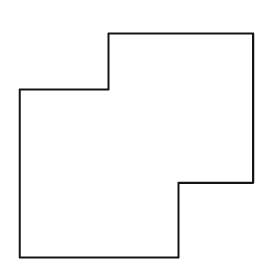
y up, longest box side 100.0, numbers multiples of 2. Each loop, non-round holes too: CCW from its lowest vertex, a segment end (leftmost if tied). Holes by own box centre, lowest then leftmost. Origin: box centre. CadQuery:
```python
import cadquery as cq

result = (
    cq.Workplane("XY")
    .moveTo(-50.0, -48.0)
    .lineTo(18.0, -48.0)
    .lineTo(18.0, -16.0)
    .lineTo(50.0, -16.0)
    .lineTo(50.0, 48.0)
    .lineTo(-12.0, 48.0)
    .lineTo(-12.0, 24.0)
    .lineTo(-50.0, 24.0)
    .close()
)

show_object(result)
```